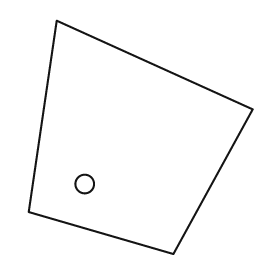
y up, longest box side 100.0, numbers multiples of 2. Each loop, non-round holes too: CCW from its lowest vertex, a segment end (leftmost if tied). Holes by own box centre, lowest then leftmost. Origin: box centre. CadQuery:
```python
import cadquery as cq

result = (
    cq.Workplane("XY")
    .moveTo(14.0, -50.0)
    .lineTo(48.0, 12.0)
    .lineTo(-36.0, 50.0)
    .lineTo(-48.0, -32.0)
    .close()
    .moveTo(-24.0, -20.0)
    .circle(4.0)
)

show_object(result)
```